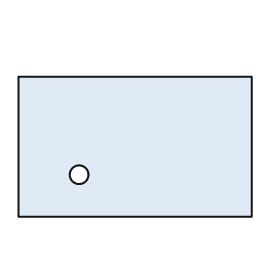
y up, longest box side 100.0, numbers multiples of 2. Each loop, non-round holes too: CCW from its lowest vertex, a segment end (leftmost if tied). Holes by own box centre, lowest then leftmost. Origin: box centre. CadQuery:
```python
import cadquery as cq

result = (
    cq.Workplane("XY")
    .moveTo(-50.0, -30.0)
    .lineTo(50.0, -30.0)
    .lineTo(50.0, 30.0)
    .lineTo(-50.0, 30.0)
    .close()
    .moveTo(-24.0, -12.0)
    .circle(4.0)
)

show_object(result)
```